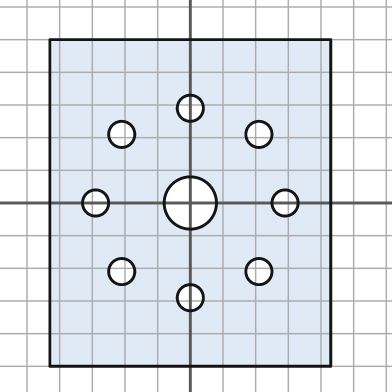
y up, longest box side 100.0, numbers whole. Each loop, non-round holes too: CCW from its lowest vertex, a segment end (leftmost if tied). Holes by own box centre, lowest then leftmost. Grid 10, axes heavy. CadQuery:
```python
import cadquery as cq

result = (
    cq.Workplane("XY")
    .moveTo(-43.0, -50.0)
    .lineTo(43.0, -50.0)
    .lineTo(43.0, 50.0)
    .lineTo(-43.0, 50.0)
    .close()
    .moveTo(0.0, -29.0)
    .circle(4.0)
    .moveTo(-21.0, -21.0)
    .circle(4.0)
    .moveTo(21.0, -21.0)
    .circle(4.0)
    .moveTo(-29.0, 0.0)
    .circle(4.0)
    .moveTo(0.0, 0.0)
    .circle(8.0)
    .moveTo(29.0, 0.0)
    .circle(4.0)
    .moveTo(-21.0, 21.0)
    .circle(4.0)
    .moveTo(21.0, 21.0)
    .circle(4.0)
    .moveTo(0.0, 29.0)
    .circle(4.0)
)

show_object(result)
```